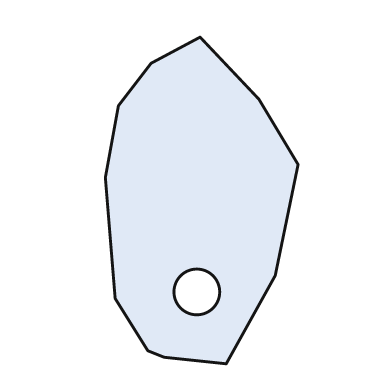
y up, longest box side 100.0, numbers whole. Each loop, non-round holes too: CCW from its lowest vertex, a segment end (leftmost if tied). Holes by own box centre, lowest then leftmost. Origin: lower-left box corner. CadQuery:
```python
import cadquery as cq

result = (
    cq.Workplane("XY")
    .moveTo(37.0, 0.0)
    .lineTo(52.0, 27.0)
    .lineTo(59.0, 61.0)
    .lineTo(47.0, 81.0)
    .lineTo(29.0, 100.0)
    .lineTo(14.0, 92.0)
    .lineTo(4.0, 79.0)
    .lineTo(0.0, 57.0)
    .lineTo(3.0, 20.0)
    .lineTo(13.0, 4.0)
    .lineTo(18.0, 2.0)
    .close()
    .moveTo(28.0, 22.0)
    .circle(7.0)
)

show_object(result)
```